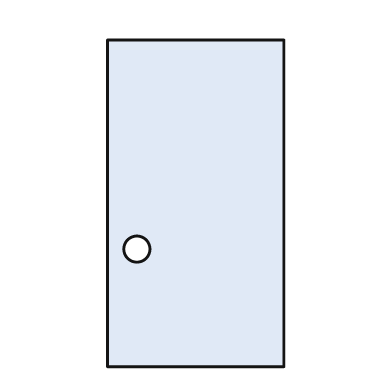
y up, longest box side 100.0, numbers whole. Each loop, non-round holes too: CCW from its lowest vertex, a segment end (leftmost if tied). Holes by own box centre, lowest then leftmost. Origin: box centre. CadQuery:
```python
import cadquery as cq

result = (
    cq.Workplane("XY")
    .moveTo(-27.0, -50.0)
    .lineTo(27.0, -50.0)
    .lineTo(27.0, 50.0)
    .lineTo(-27.0, 50.0)
    .close()
    .moveTo(-18.0, -14.0)
    .circle(4.0)
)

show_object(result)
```